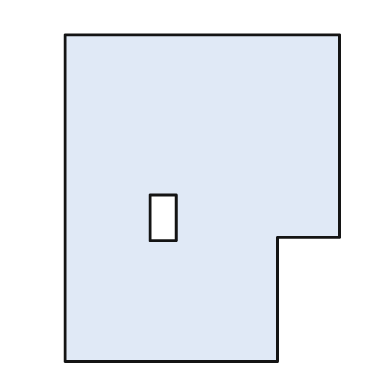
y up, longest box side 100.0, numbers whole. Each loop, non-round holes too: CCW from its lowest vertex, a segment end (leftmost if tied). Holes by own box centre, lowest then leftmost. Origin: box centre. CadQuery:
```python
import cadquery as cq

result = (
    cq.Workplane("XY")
    .moveTo(-42.0, -50.0)
    .lineTo(23.0, -50.0)
    .lineTo(23.0, -12.0)
    .lineTo(42.0, -12.0)
    .lineTo(42.0, 50.0)
    .lineTo(-42.0, 50.0)
    .close()
    .moveTo(-16.0, -13.0)
    .lineTo(-8.0, -13.0)
    .lineTo(-8.0, 1.0)
    .lineTo(-16.0, 1.0)
    .close()
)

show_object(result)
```